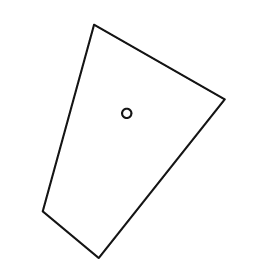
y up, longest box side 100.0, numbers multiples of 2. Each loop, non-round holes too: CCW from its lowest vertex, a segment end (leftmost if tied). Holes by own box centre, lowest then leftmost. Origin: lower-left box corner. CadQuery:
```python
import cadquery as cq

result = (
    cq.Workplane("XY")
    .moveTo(24.0, 0.0)
    .lineTo(78.0, 68.0)
    .lineTo(22.0, 100.0)
    .lineTo(0.0, 20.0)
    .close()
    .moveTo(36.0, 62.0)
    .circle(2.0)
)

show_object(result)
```